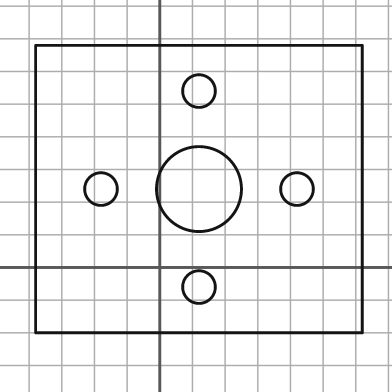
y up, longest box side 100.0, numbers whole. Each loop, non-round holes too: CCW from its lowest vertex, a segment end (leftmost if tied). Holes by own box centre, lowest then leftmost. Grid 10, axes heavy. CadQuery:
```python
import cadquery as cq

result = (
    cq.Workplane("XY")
    .moveTo(-38.0, -20.0)
    .lineTo(62.0, -20.0)
    .lineTo(62.0, 68.0)
    .lineTo(-38.0, 68.0)
    .close()
    .moveTo(12.0, -6.0)
    .circle(5.0)
    .moveTo(-18.0, 24.0)
    .circle(5.0)
    .moveTo(12.0, 24.0)
    .circle(13.0)
    .moveTo(42.0, 24.0)
    .circle(5.0)
    .moveTo(12.0, 54.0)
    .circle(5.0)
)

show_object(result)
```